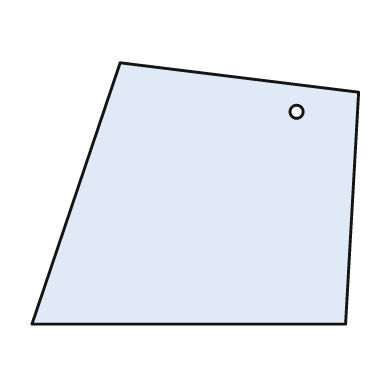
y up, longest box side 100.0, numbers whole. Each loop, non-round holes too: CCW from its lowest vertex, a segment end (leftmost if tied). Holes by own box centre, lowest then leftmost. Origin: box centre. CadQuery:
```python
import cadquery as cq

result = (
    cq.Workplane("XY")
    .moveTo(-50.0, -40.0)
    .lineTo(46.0, -40.0)
    .lineTo(50.0, 31.0)
    .lineTo(-23.0, 40.0)
    .close()
    .moveTo(31.0, 25.0)
    .circle(2.0)
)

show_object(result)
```